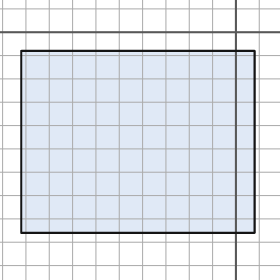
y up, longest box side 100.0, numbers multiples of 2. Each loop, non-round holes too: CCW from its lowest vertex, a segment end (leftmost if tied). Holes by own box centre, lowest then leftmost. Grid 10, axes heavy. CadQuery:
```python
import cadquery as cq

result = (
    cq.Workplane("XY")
    .moveTo(-92.0, -86.0)
    .lineTo(8.0, -86.0)
    .lineTo(8.0, -8.0)
    .lineTo(-92.0, -8.0)
    .close()
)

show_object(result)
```